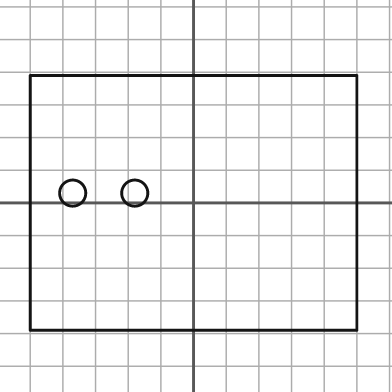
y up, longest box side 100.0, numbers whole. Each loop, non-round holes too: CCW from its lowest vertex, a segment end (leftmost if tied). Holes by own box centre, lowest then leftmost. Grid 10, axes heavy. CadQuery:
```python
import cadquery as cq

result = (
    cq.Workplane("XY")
    .moveTo(-50.0, -39.0)
    .lineTo(50.0, -39.0)
    .lineTo(50.0, 39.0)
    .lineTo(-50.0, 39.0)
    .close()
    .moveTo(-37.0, 3.0)
    .circle(4.0)
    .moveTo(-18.0, 3.0)
    .circle(4.0)
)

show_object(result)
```